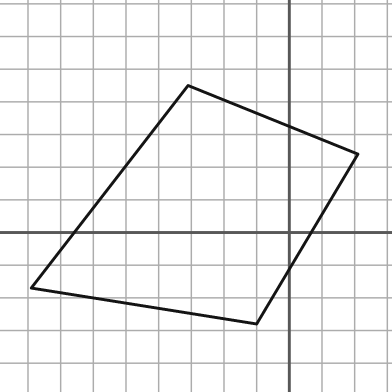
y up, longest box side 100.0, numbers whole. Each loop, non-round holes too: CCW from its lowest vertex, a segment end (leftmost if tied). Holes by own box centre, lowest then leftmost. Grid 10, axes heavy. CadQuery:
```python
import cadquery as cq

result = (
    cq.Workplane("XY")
    .moveTo(-10.0, -28.0)
    .lineTo(21.0, 24.0)
    .lineTo(-31.0, 45.0)
    .lineTo(-79.0, -17.0)
    .close()
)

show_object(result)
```